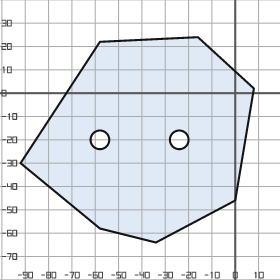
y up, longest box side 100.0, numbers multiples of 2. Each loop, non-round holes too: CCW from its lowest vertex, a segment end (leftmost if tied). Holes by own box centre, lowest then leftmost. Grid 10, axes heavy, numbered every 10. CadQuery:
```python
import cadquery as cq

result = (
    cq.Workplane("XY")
    .moveTo(-34.0, -64.0)
    .lineTo(0.0, -46.0)
    .lineTo(8.0, 2.0)
    .lineTo(-16.0, 24.0)
    .lineTo(-58.0, 22.0)
    .lineTo(-92.0, -30.0)
    .lineTo(-58.0, -58.0)
    .close()
    .moveTo(-58.0, -20.0)
    .circle(4.0)
    .moveTo(-24.0, -20.0)
    .circle(4.0)
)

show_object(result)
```